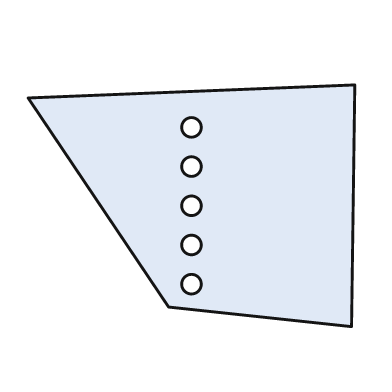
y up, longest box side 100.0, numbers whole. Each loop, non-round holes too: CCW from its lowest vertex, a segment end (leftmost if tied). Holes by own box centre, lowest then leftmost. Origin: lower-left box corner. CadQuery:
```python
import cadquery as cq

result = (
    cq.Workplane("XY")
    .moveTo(99.0, 0.0)
    .lineTo(100.0, 74.0)
    .lineTo(0.0, 70.0)
    .lineTo(43.0, 6.0)
    .close()
    .moveTo(50.0, 13.0)
    .circle(3.0)
    .moveTo(50.0, 25.0)
    .circle(3.0)
    .moveTo(50.0, 37.0)
    .circle(3.0)
    .moveTo(50.0, 49.0)
    .circle(3.0)
    .moveTo(50.0, 61.0)
    .circle(3.0)
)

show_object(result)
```